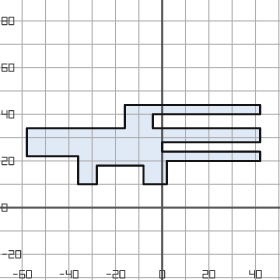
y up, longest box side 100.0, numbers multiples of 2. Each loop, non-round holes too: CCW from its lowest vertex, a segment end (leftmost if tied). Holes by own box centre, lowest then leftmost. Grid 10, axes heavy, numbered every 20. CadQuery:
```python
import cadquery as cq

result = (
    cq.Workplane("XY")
    .moveTo(-36.0, 10.0)
    .lineTo(-28.0, 10.0)
    .lineTo(-28.0, 18.0)
    .lineTo(-8.0, 18.0)
    .lineTo(-8.0, 10.0)
    .lineTo(2.0, 10.0)
    .lineTo(2.0, 20.0)
    .lineTo(42.0, 20.0)
    .lineTo(42.0, 24.0)
    .lineTo(0.0, 24.0)
    .lineTo(0.0, 28.0)
    .lineTo(42.0, 28.0)
    .lineTo(42.0, 34.0)
    .lineTo(-4.0, 34.0)
    .lineTo(-4.0, 40.0)
    .lineTo(42.0, 40.0)
    .lineTo(42.0, 44.0)
    .lineTo(-16.0, 44.0)
    .lineTo(-16.0, 34.0)
    .lineTo(-58.0, 34.0)
    .lineTo(-58.0, 22.0)
    .lineTo(-36.0, 22.0)
    .close()
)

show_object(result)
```